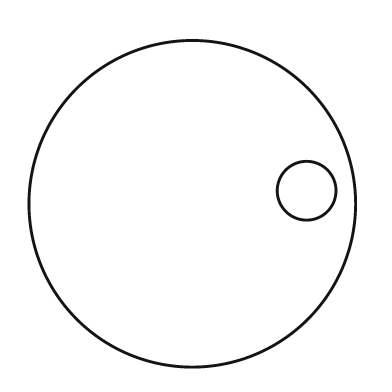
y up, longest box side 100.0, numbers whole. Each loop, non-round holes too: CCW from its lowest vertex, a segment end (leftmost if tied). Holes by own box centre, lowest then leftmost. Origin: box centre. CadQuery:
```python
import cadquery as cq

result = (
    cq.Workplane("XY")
    .moveTo(0.0, 0.0)
    .circle(50.0)
    .moveTo(35.0, 4.0)
    .circle(9.0)
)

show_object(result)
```